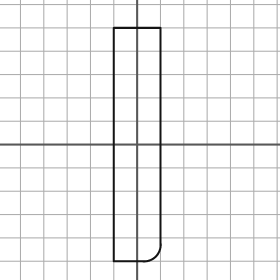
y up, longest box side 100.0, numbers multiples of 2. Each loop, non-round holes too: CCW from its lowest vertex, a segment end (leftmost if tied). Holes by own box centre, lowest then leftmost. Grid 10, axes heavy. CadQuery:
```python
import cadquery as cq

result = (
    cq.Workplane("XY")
    .moveTo(-10.0, -50.0)
    .lineTo(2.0, -50.0)
    .threePointArc((8.0, -48.0), (10.0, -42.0))
    .lineTo(10.0, 50.0)
    .lineTo(-10.0, 50.0)
    .close()
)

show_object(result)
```